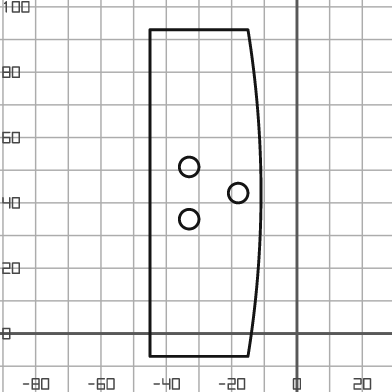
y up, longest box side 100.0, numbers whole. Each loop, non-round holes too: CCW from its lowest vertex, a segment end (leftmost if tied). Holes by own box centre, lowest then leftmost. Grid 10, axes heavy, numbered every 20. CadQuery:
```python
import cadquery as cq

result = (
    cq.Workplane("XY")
    .moveTo(-45.0, -7.0)
    .lineTo(-15.0, -7.0)
    .threePointArc((-11.0, 43.0), (-15.0, 93.0))
    .lineTo(-45.0, 93.0)
    .close()
    .moveTo(-33.0, 35.0)
    .circle(3.0)
    .moveTo(-18.0, 43.0)
    .circle(3.0)
    .moveTo(-33.0, 51.0)
    .circle(3.0)
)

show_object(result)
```